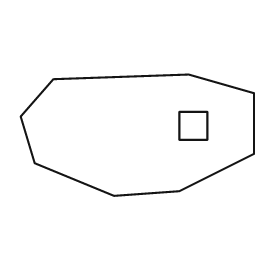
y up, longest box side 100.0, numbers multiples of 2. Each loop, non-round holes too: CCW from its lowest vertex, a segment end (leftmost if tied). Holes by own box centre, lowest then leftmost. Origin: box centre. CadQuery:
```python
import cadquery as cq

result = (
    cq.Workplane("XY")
    .moveTo(-10.0, -26.0)
    .lineTo(18.0, -24.0)
    .lineTo(50.0, -8.0)
    .lineTo(50.0, 18.0)
    .lineTo(22.0, 26.0)
    .lineTo(-36.0, 24.0)
    .lineTo(-50.0, 8.0)
    .lineTo(-44.0, -12.0)
    .close()
    .moveTo(18.0, -2.0)
    .lineTo(30.0, -2.0)
    .lineTo(30.0, 10.0)
    .lineTo(18.0, 10.0)
    .close()
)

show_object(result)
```